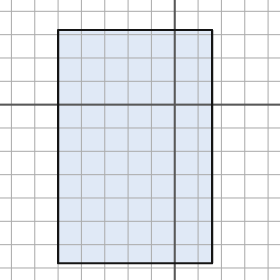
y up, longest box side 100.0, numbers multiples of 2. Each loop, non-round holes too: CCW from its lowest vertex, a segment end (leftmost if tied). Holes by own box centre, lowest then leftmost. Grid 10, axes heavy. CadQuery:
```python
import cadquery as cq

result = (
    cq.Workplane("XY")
    .moveTo(-50.0, -68.0)
    .lineTo(16.0, -68.0)
    .lineTo(16.0, 32.0)
    .lineTo(-50.0, 32.0)
    .close()
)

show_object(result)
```